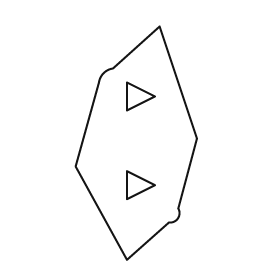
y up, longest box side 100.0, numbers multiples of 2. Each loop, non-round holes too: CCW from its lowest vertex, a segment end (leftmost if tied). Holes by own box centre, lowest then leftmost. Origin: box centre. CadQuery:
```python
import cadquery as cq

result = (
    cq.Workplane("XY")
    .moveTo(-4.0, -50.0)
    .lineTo(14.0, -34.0)
    .threePointArc((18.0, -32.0), (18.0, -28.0))
    .lineTo(26.0, 2.0)
    .lineTo(10.0, 50.0)
    .lineTo(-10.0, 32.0)
    .threePointArc((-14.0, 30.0), (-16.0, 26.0))
    .lineTo(-26.0, -10.0)
    .close()
    .moveTo(-4.0, -24.0)
    .lineTo(8.0, -18.0)
    .lineTo(-4.0, -12.0)
    .close()
    .moveTo(-4.0, 14.0)
    .lineTo(8.0, 20.0)
    .lineTo(-4.0, 26.0)
    .close()
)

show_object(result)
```